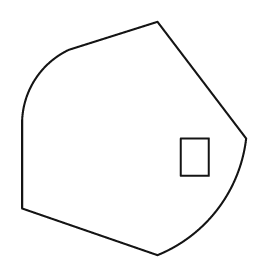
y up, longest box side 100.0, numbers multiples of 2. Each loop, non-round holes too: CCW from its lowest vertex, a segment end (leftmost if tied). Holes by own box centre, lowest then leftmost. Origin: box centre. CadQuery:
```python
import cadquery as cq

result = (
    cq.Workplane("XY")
    .moveTo(10.0, -50.0)
    .threePointArc((36.0, -30.0), (48.0, 0.0))
    .lineTo(10.0, 50.0)
    .lineTo(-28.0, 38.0)
    .threePointArc((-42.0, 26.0), (-48.0, 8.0))
    .lineTo(-48.0, -30.0)
    .close()
    .moveTo(20.0, -16.0)
    .lineTo(32.0, -16.0)
    .lineTo(32.0, 0.0)
    .lineTo(20.0, 0.0)
    .close()
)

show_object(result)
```